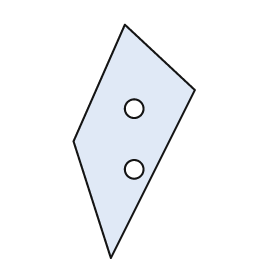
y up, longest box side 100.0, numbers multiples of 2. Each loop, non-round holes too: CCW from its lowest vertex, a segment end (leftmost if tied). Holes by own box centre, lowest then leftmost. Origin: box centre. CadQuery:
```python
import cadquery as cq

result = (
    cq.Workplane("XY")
    .moveTo(-10.0, -50.0)
    .lineTo(26.0, 22.0)
    .lineTo(-4.0, 50.0)
    .lineTo(-26.0, 0.0)
    .close()
    .moveTo(0.0, -12.0)
    .circle(4.0)
    .moveTo(0.0, 14.0)
    .circle(4.0)
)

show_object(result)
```